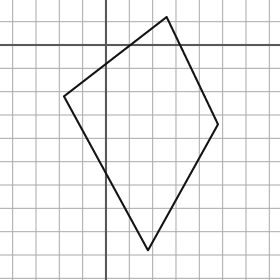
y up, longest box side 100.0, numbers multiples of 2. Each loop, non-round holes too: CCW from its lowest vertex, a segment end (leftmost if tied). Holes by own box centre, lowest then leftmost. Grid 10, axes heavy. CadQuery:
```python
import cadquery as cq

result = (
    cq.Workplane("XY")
    .moveTo(18.0, -88.0)
    .lineTo(48.0, -34.0)
    .lineTo(26.0, 12.0)
    .lineTo(-18.0, -22.0)
    .close()
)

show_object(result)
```